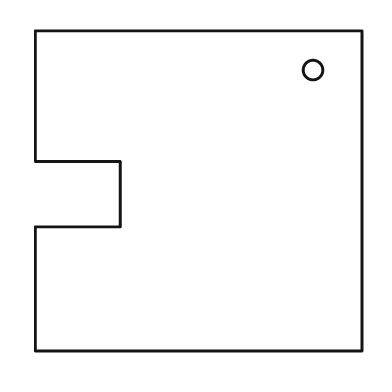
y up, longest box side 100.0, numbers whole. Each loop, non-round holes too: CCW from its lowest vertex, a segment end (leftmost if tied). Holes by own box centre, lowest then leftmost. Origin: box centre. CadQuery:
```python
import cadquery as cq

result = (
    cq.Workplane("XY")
    .moveTo(-50.0, -49.0)
    .lineTo(50.0, -49.0)
    .lineTo(50.0, 49.0)
    .lineTo(-50.0, 49.0)
    .lineTo(-50.0, 9.0)
    .lineTo(-24.0, 9.0)
    .lineTo(-24.0, -11.0)
    .lineTo(-50.0, -11.0)
    .close()
    .moveTo(35.0, 37.0)
    .circle(3.0)
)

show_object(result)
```